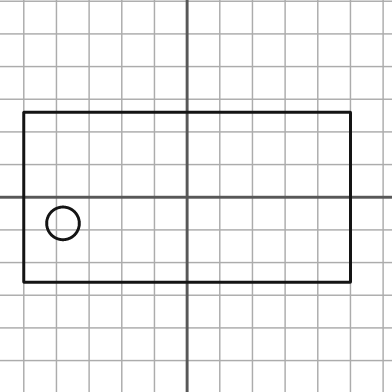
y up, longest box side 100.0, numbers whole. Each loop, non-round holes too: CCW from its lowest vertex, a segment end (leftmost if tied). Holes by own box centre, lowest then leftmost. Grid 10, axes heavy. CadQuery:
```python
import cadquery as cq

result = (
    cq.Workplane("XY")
    .moveTo(-50.0, -26.0)
    .lineTo(50.0, -26.0)
    .lineTo(50.0, 26.0)
    .lineTo(-50.0, 26.0)
    .close()
    .moveTo(-38.0, -8.0)
    .circle(5.0)
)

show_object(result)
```